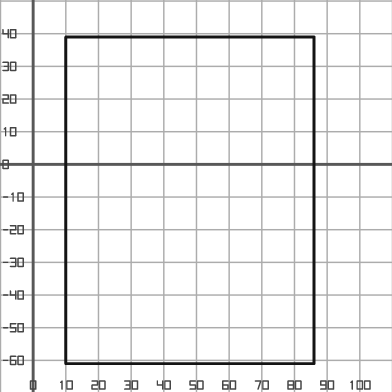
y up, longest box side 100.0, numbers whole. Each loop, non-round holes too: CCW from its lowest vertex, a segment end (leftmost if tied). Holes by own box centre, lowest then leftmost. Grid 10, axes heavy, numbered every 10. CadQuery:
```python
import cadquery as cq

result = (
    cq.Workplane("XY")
    .moveTo(10.0, -61.0)
    .lineTo(86.0, -61.0)
    .lineTo(86.0, 39.0)
    .lineTo(10.0, 39.0)
    .close()
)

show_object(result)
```